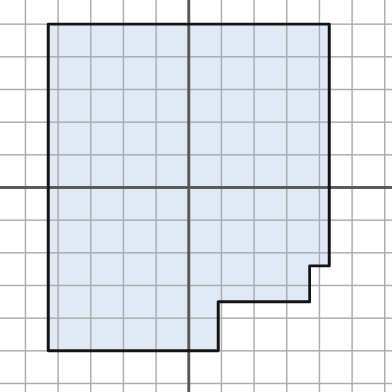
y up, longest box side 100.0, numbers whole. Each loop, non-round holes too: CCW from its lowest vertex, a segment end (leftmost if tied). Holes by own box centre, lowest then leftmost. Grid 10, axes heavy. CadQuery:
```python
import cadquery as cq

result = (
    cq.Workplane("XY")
    .moveTo(-43.0, -50.0)
    .lineTo(9.0, -50.0)
    .lineTo(9.0, -35.0)
    .lineTo(37.0, -35.0)
    .lineTo(37.0, -24.0)
    .lineTo(43.0, -24.0)
    .lineTo(43.0, 50.0)
    .lineTo(-43.0, 50.0)
    .close()
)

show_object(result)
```